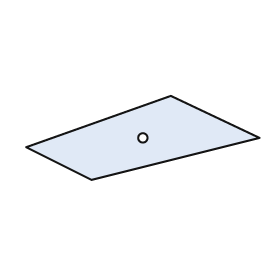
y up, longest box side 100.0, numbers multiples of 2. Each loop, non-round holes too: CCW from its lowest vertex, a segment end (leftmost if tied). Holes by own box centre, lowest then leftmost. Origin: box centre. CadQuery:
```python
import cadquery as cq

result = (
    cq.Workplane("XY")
    .moveTo(-22.0, -18.0)
    .lineTo(50.0, 0.0)
    .lineTo(12.0, 18.0)
    .lineTo(-50.0, -4.0)
    .close()
    .moveTo(0.0, 0.0)
    .circle(2.0)
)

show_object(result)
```